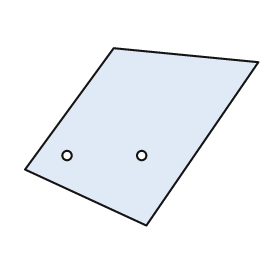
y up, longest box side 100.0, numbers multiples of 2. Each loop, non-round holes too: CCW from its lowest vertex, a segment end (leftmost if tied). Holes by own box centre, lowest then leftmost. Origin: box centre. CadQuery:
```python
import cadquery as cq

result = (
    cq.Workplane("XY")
    .moveTo(2.0, -38.0)
    .lineTo(50.0, 32.0)
    .lineTo(-12.0, 38.0)
    .lineTo(-50.0, -14.0)
    .close()
    .moveTo(-32.0, -8.0)
    .circle(2.0)
    .moveTo(0.0, -8.0)
    .circle(2.0)
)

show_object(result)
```